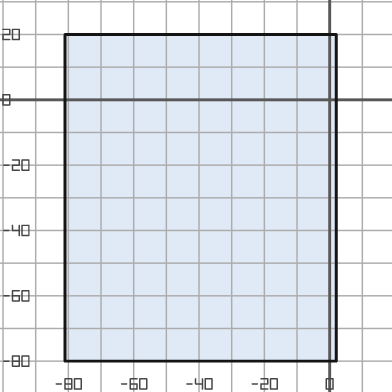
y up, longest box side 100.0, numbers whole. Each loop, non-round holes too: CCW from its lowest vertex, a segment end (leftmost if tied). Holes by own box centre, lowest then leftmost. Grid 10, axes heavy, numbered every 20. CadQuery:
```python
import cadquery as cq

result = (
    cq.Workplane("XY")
    .moveTo(-81.0, -80.0)
    .lineTo(2.0, -80.0)
    .lineTo(2.0, 20.0)
    .lineTo(-81.0, 20.0)
    .close()
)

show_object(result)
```